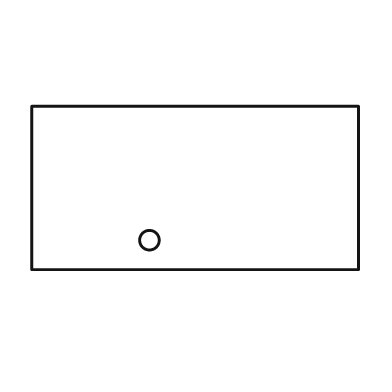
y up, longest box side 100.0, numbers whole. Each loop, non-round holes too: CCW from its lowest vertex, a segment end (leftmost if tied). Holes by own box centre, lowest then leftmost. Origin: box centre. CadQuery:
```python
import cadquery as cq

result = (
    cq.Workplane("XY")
    .moveTo(-50.0, -25.0)
    .lineTo(50.0, -25.0)
    .lineTo(50.0, 25.0)
    .lineTo(-50.0, 25.0)
    .close()
    .moveTo(-14.0, -16.0)
    .circle(3.0)
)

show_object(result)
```